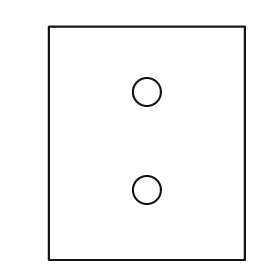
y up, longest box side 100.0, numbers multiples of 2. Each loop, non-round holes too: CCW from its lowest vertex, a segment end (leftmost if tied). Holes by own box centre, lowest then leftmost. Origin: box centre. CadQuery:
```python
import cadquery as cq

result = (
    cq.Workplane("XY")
    .moveTo(-42.0, -50.0)
    .lineTo(42.0, -50.0)
    .lineTo(42.0, 50.0)
    .lineTo(-42.0, 50.0)
    .close()
    .moveTo(0.0, -20.0)
    .circle(6.0)
    .moveTo(0.0, 22.0)
    .circle(6.0)
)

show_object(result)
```